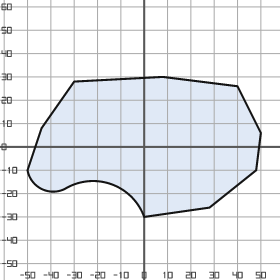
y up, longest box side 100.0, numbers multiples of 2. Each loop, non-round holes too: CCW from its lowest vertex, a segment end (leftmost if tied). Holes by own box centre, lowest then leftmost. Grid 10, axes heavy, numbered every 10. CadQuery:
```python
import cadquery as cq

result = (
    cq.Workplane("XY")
    .moveTo(0.0, -30.0)
    .lineTo(28.0, -26.0)
    .lineTo(48.0, -10.0)
    .lineTo(50.0, 6.0)
    .lineTo(40.0, 26.0)
    .lineTo(8.0, 30.0)
    .lineTo(-30.0, 28.0)
    .lineTo(-44.0, 8.0)
    .lineTo(-50.0, -10.0)
    .threePointArc((-44.0, -18.0), (-34.0, -18.0))
    .threePointArc((-14.0, -16.0), (0.0, -30.0))
    .close()
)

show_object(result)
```